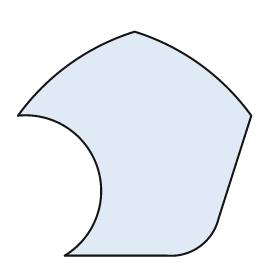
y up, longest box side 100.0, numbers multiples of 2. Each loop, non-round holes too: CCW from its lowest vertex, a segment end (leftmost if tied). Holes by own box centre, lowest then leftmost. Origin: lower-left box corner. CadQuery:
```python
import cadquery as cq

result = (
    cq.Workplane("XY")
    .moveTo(20.0, 0.0)
    .lineTo(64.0, 0.0)
    .threePointArc((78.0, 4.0), (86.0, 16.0))
    .lineTo(100.0, 60.0)
    .threePointArc((78.0, 82.0), (50.0, 96.0))
    .threePointArc((22.0, 82.0), (0.0, 60.0))
    .threePointArc((34.0, 38.0), (20.0, 0.0))
    .close()
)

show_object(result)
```